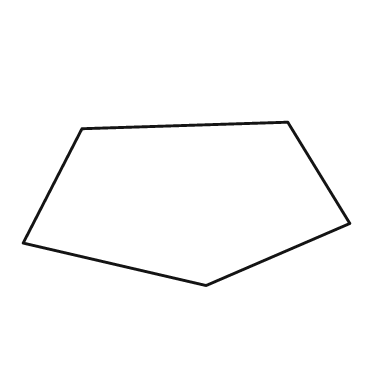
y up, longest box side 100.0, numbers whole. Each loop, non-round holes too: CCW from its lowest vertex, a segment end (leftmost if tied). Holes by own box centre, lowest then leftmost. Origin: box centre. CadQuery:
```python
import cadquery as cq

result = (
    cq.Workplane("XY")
    .moveTo(6.0, -25.0)
    .lineTo(50.0, -6.0)
    .lineTo(31.0, 25.0)
    .lineTo(-32.0, 23.0)
    .lineTo(-50.0, -12.0)
    .close()
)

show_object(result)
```